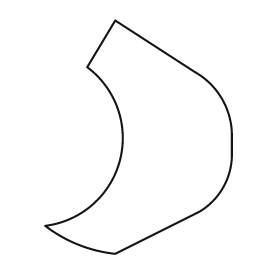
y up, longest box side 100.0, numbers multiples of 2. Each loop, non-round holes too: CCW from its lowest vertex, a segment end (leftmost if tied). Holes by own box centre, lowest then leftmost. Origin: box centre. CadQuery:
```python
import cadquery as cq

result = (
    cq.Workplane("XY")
    .moveTo(-10.0, -50.0)
    .lineTo(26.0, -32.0)
    .threePointArc((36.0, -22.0), (40.0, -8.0))
    .lineTo(40.0, 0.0)
    .threePointArc((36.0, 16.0), (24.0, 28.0))
    .lineTo(-10.0, 50.0)
    .lineTo(-22.0, 30.0)
    .threePointArc((-8.0, -10.0), (-40.0, -38.0))
    .threePointArc((-26.0, -46.0), (-10.0, -50.0))
    .close()
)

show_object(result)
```